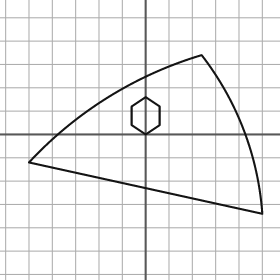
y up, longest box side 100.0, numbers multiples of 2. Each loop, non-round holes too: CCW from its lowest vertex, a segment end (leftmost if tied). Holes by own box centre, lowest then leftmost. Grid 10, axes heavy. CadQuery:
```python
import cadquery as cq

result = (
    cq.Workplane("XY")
    .moveTo(50.0, -34.0)
    .threePointArc((42.0, 2.0), (24.0, 34.0))
    .threePointArc((-16.0, 16.0), (-50.0, -12.0))
    .close()
    .moveTo(0.0, 0.0)
    .lineTo(6.0, 4.0)
    .lineTo(6.0, 12.0)
    .lineTo(0.0, 16.0)
    .lineTo(-6.0, 12.0)
    .lineTo(-6.0, 4.0)
    .close()
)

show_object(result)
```